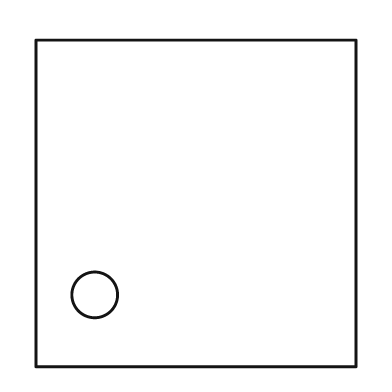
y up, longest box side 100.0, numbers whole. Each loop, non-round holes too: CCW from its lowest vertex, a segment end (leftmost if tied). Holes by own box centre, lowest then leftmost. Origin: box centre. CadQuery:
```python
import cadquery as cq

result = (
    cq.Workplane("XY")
    .moveTo(-49.0, -50.0)
    .lineTo(49.0, -50.0)
    .lineTo(49.0, 50.0)
    .lineTo(-49.0, 50.0)
    .close()
    .moveTo(-31.0, -28.0)
    .circle(7.0)
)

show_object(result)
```